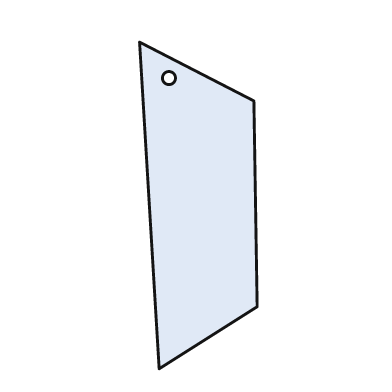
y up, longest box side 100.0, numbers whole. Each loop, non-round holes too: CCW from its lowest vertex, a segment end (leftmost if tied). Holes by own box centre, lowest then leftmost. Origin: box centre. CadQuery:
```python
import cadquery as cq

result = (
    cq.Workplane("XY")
    .moveTo(-12.0, -50.0)
    .lineTo(18.0, -31.0)
    .lineTo(17.0, 32.0)
    .lineTo(-18.0, 50.0)
    .close()
    .moveTo(-9.0, 39.0)
    .circle(2.0)
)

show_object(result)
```